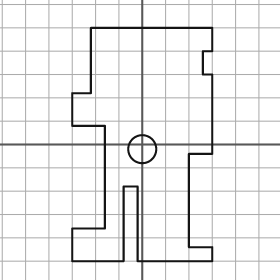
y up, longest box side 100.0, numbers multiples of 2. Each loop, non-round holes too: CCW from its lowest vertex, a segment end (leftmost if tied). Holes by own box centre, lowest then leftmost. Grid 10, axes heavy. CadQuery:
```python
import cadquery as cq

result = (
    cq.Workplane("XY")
    .moveTo(-30.0, -50.0)
    .lineTo(-8.0, -50.0)
    .lineTo(-8.0, -18.0)
    .lineTo(-2.0, -18.0)
    .lineTo(-2.0, -50.0)
    .lineTo(30.0, -50.0)
    .lineTo(30.0, -44.0)
    .lineTo(20.0, -44.0)
    .lineTo(20.0, -4.0)
    .lineTo(30.0, -4.0)
    .lineTo(30.0, 30.0)
    .lineTo(26.0, 30.0)
    .lineTo(26.0, 40.0)
    .lineTo(30.0, 40.0)
    .lineTo(30.0, 50.0)
    .lineTo(-22.0, 50.0)
    .lineTo(-22.0, 22.0)
    .lineTo(-30.0, 22.0)
    .lineTo(-30.0, 8.0)
    .lineTo(-16.0, 8.0)
    .lineTo(-16.0, -36.0)
    .lineTo(-30.0, -36.0)
    .close()
    .moveTo(0.0, -2.0)
    .circle(6.0)
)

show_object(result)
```